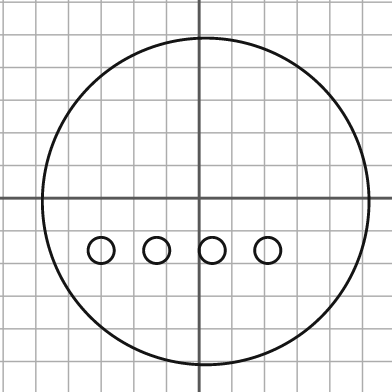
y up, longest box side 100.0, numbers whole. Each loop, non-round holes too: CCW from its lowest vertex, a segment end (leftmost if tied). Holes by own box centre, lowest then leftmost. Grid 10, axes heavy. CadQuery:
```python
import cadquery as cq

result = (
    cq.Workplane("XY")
    .moveTo(2.0, -1.0)
    .circle(50.0)
    .moveTo(-30.0, -16.0)
    .circle(4.0)
    .moveTo(-13.0, -16.0)
    .circle(4.0)
    .moveTo(4.0, -16.0)
    .circle(4.0)
    .moveTo(21.0, -16.0)
    .circle(4.0)
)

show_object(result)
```